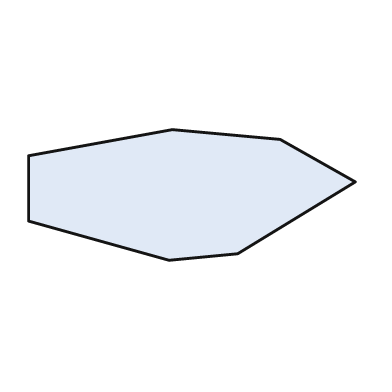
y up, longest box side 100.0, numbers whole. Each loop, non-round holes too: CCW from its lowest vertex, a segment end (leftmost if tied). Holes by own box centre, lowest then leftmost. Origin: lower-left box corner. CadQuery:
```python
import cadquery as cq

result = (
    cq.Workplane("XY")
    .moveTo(43.0, 0.0)
    .lineTo(64.0, 2.0)
    .lineTo(100.0, 24.0)
    .lineTo(77.0, 37.0)
    .lineTo(44.0, 40.0)
    .lineTo(0.0, 32.0)
    .lineTo(0.0, 12.0)
    .close()
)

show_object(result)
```